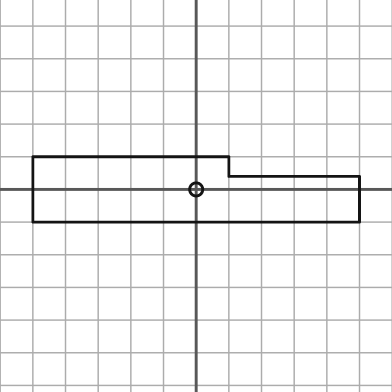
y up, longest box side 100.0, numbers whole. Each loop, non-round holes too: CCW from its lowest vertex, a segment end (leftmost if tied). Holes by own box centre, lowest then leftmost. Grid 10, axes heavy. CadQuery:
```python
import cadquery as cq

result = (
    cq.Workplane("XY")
    .moveTo(-50.0, -10.0)
    .lineTo(50.0, -10.0)
    .lineTo(50.0, 4.0)
    .lineTo(10.0, 4.0)
    .lineTo(10.0, 10.0)
    .lineTo(-50.0, 10.0)
    .close()
    .moveTo(0.0, 0.0)
    .circle(2.0)
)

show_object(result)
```